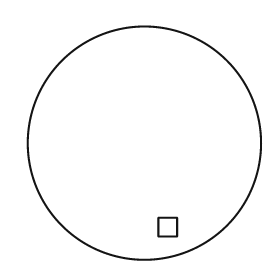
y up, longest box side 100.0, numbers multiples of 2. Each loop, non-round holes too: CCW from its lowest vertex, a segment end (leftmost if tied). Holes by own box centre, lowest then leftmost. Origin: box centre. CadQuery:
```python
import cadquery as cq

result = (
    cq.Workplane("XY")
    .moveTo(0.0, 0.0)
    .circle(50.0)
    .moveTo(6.0, -40.0)
    .lineTo(14.0, -40.0)
    .lineTo(14.0, -32.0)
    .lineTo(6.0, -32.0)
    .close()
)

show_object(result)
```